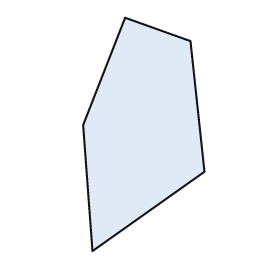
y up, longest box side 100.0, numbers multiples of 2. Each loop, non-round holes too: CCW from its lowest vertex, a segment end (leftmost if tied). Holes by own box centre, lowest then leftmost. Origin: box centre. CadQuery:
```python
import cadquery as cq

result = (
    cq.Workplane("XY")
    .moveTo(-22.0, -50.0)
    .lineTo(26.0, -16.0)
    .lineTo(20.0, 40.0)
    .lineTo(-8.0, 50.0)
    .lineTo(-26.0, 4.0)
    .close()
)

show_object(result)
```